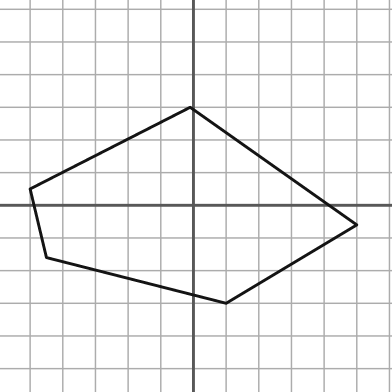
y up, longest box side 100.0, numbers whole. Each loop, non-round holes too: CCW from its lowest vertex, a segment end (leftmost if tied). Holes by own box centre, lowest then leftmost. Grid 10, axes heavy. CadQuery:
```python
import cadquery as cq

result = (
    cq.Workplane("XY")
    .moveTo(10.0, -30.0)
    .lineTo(50.0, -6.0)
    .lineTo(-1.0, 30.0)
    .lineTo(-50.0, 5.0)
    .lineTo(-45.0, -16.0)
    .close()
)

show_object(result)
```